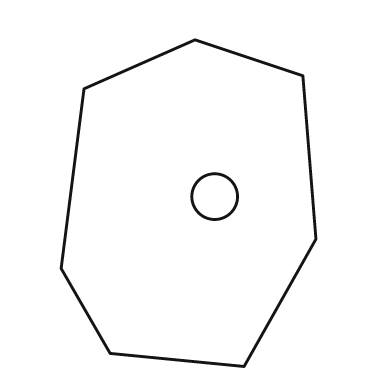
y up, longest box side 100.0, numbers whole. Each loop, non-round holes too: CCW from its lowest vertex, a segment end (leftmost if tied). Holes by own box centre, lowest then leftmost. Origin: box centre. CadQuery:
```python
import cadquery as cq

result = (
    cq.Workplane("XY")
    .moveTo(17.0, -50.0)
    .lineTo(39.0, -11.0)
    .lineTo(35.0, 39.0)
    .lineTo(2.0, 50.0)
    .lineTo(-32.0, 35.0)
    .lineTo(-39.0, -20.0)
    .lineTo(-24.0, -46.0)
    .close()
    .moveTo(8.0, 2.0)
    .circle(7.0)
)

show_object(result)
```